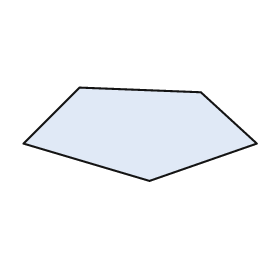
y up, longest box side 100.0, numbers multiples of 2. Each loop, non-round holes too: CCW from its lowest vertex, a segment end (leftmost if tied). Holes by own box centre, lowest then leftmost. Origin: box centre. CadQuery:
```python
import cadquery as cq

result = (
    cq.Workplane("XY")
    .moveTo(4.0, -20.0)
    .lineTo(50.0, -4.0)
    .lineTo(26.0, 18.0)
    .lineTo(-26.0, 20.0)
    .lineTo(-50.0, -4.0)
    .close()
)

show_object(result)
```